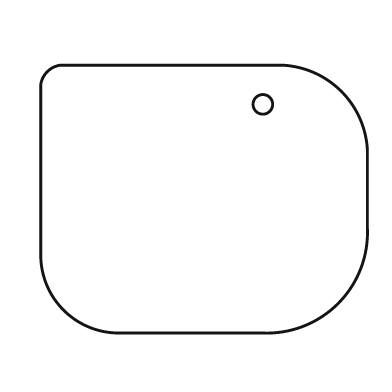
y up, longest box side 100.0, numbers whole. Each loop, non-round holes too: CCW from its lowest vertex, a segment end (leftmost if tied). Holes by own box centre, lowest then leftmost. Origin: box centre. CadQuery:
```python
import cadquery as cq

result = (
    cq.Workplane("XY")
    .moveTo(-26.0, -41.0)
    .lineTo(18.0, -41.0)
    .threePointArc((41.0, -32.0), (50.0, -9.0))
    .lineTo(50.0, 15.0)
    .threePointArc((42.0, 33.0), (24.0, 41.0))
    .lineTo(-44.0, 41.0)
    .threePointArc((-48.0, 39.0), (-50.0, 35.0))
    .lineTo(-50.0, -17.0)
    .threePointArc((-43.0, -34.0), (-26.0, -41.0))
    .close()
    .moveTo(18.0, 29.0)
    .circle(3.0)
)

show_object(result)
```